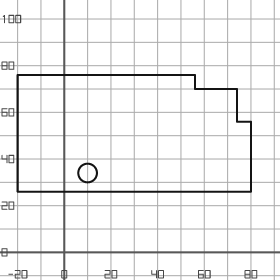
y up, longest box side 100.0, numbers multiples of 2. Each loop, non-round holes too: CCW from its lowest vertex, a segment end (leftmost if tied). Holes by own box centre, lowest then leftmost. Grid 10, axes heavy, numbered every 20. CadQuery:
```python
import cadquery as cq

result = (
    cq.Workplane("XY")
    .moveTo(-20.0, 26.0)
    .lineTo(80.0, 26.0)
    .lineTo(80.0, 56.0)
    .lineTo(74.0, 56.0)
    .lineTo(74.0, 70.0)
    .lineTo(56.0, 70.0)
    .lineTo(56.0, 76.0)
    .lineTo(-20.0, 76.0)
    .close()
    .moveTo(10.0, 34.0)
    .circle(4.0)
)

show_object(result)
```